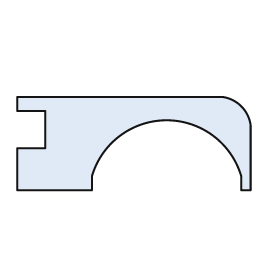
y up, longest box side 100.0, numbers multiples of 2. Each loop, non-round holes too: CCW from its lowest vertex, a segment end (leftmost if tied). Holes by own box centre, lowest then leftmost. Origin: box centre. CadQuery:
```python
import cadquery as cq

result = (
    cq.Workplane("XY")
    .moveTo(-50.0, -20.0)
    .lineTo(-18.0, -20.0)
    .lineTo(-18.0, -14.0)
    .threePointArc((14.0, 10.0), (46.0, -14.0))
    .lineTo(46.0, -20.0)
    .lineTo(50.0, -20.0)
    .lineTo(50.0, 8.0)
    .threePointArc((46.0, 16.0), (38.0, 20.0))
    .lineTo(-50.0, 20.0)
    .lineTo(-50.0, 14.0)
    .lineTo(-38.0, 14.0)
    .lineTo(-38.0, -2.0)
    .lineTo(-50.0, -2.0)
    .close()
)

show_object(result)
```